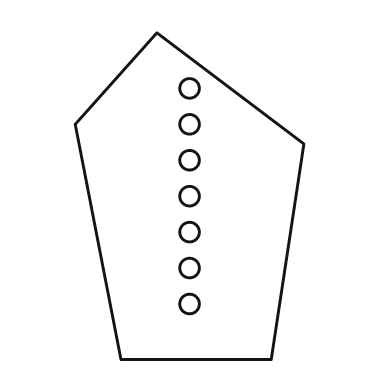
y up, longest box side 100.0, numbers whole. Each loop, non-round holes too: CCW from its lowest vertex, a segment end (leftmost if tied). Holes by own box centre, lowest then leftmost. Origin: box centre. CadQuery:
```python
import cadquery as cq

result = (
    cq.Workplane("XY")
    .moveTo(-21.0, -50.0)
    .lineTo(25.0, -50.0)
    .lineTo(35.0, 16.0)
    .lineTo(-10.0, 50.0)
    .lineTo(-35.0, 22.0)
    .close()
    .moveTo(0.0, -33.0)
    .circle(3.0)
    .moveTo(0.0, -22.0)
    .circle(3.0)
    .moveTo(0.0, -11.0)
    .circle(3.0)
    .moveTo(0.0, 0.0)
    .circle(3.0)
    .moveTo(0.0, 11.0)
    .circle(3.0)
    .moveTo(0.0, 22.0)
    .circle(3.0)
    .moveTo(0.0, 33.0)
    .circle(3.0)
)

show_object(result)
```